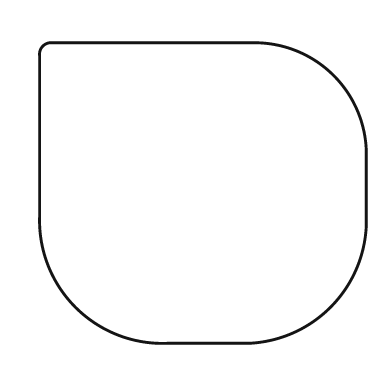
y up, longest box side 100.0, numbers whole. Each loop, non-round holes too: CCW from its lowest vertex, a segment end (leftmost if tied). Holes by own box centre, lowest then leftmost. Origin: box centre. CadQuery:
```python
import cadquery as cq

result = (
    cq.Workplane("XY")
    .moveTo(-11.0, -46.0)
    .lineTo(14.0, -46.0)
    .threePointArc((39.0, -35.0), (50.0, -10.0))
    .lineTo(50.0, 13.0)
    .threePointArc((40.0, 36.0), (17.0, 46.0))
    .lineTo(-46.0, 46.0)
    .threePointArc((-49.0, 45.0), (-50.0, 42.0))
    .lineTo(-50.0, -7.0)
    .threePointArc((-39.0, -35.0), (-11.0, -46.0))
    .close()
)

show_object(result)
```